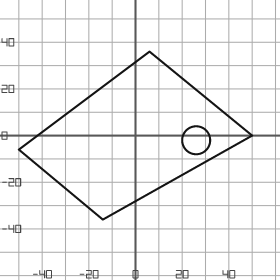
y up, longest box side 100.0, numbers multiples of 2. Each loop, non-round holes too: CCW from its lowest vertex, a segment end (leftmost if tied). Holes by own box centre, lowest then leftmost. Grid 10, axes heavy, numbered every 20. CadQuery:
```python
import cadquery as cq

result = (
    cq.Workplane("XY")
    .moveTo(-14.0, -36.0)
    .lineTo(50.0, 0.0)
    .lineTo(6.0, 36.0)
    .lineTo(-50.0, -6.0)
    .close()
    .moveTo(26.0, -2.0)
    .circle(6.0)
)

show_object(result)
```